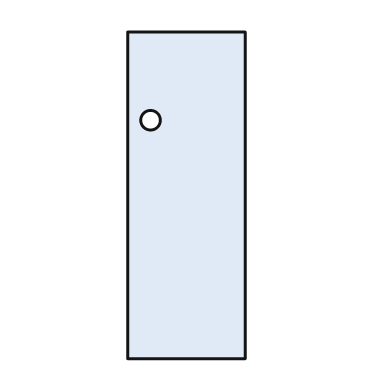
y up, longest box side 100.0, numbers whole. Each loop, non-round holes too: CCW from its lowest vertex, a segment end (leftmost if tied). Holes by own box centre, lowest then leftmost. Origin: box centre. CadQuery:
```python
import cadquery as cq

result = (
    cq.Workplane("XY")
    .moveTo(-18.0, -50.0)
    .lineTo(18.0, -50.0)
    .lineTo(18.0, 50.0)
    .lineTo(-18.0, 50.0)
    .close()
    .moveTo(-11.0, 23.0)
    .circle(3.0)
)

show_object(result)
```